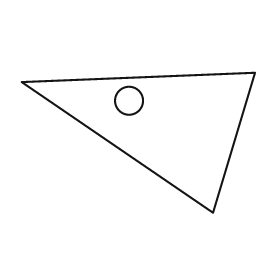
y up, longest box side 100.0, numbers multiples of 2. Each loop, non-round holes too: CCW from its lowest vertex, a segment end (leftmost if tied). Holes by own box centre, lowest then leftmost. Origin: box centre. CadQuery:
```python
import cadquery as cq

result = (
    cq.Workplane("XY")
    .moveTo(32.0, -30.0)
    .lineTo(50.0, 30.0)
    .lineTo(-50.0, 26.0)
    .close()
    .moveTo(-4.0, 18.0)
    .circle(6.0)
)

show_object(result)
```